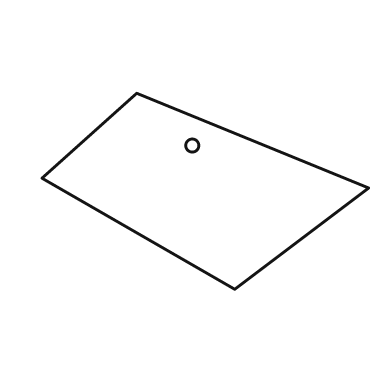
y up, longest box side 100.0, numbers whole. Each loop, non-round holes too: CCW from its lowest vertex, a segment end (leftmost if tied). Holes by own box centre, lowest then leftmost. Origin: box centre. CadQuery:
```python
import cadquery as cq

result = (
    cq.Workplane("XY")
    .moveTo(9.0, -30.0)
    .lineTo(50.0, 1.0)
    .lineTo(-21.0, 30.0)
    .lineTo(-50.0, 4.0)
    .close()
    .moveTo(-4.0, 14.0)
    .circle(2.0)
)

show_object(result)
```